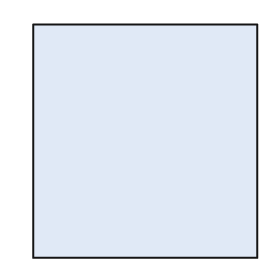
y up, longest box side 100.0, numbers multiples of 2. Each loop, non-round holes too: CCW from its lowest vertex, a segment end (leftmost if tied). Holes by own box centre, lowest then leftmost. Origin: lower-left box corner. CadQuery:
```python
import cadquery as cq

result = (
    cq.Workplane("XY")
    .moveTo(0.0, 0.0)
    .lineTo(96.0, 0.0)
    .lineTo(96.0, 100.0)
    .lineTo(0.0, 100.0)
    .close()
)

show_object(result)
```